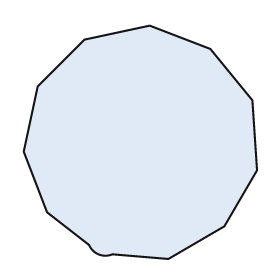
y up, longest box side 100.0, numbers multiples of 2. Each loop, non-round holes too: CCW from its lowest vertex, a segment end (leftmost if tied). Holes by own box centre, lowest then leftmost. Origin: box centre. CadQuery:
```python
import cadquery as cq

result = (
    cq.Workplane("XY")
    .moveTo(12.0, -50.0)
    .lineTo(36.0, -36.0)
    .lineTo(50.0, -12.0)
    .lineTo(48.0, 18.0)
    .lineTo(30.0, 40.0)
    .lineTo(4.0, 50.0)
    .lineTo(-24.0, 44.0)
    .lineTo(-44.0, 24.0)
    .lineTo(-50.0, -4.0)
    .lineTo(-40.0, -30.0)
    .lineTo(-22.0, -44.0)
    .threePointArc((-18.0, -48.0), (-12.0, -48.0))
    .close()
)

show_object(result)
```